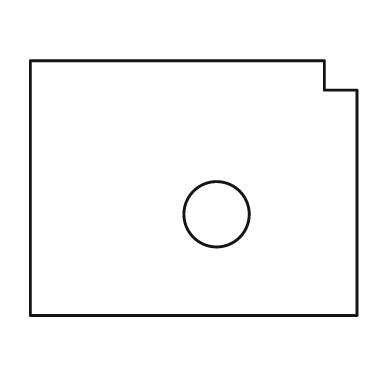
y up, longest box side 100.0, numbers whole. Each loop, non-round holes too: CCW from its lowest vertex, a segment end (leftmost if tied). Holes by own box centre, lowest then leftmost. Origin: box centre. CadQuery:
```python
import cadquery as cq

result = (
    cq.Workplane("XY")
    .moveTo(-50.0, -39.0)
    .lineTo(50.0, -39.0)
    .lineTo(50.0, 30.0)
    .lineTo(40.0, 30.0)
    .lineTo(40.0, 39.0)
    .lineTo(-50.0, 39.0)
    .close()
    .moveTo(7.0, -8.0)
    .circle(10.0)
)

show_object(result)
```